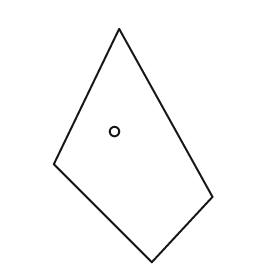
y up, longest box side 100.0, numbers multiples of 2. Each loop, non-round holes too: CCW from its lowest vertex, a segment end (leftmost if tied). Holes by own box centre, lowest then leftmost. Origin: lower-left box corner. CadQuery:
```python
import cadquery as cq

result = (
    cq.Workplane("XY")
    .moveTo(42.0, 0.0)
    .lineTo(68.0, 28.0)
    .lineTo(28.0, 100.0)
    .lineTo(0.0, 42.0)
    .close()
    .moveTo(26.0, 56.0)
    .circle(2.0)
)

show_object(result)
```